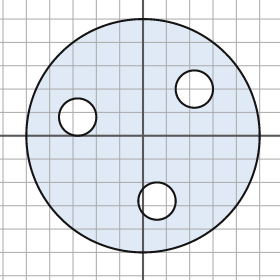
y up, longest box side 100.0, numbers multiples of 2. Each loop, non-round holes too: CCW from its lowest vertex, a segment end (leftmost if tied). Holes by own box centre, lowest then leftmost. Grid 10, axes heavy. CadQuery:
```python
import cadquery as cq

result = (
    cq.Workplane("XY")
    .moveTo(0.0, 0.0)
    .circle(50.0)
    .moveTo(6.0, -28.0)
    .circle(8.0)
    .moveTo(-28.0, 8.0)
    .circle(8.0)
    .moveTo(22.0, 20.0)
    .circle(8.0)
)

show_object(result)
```